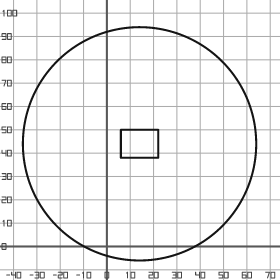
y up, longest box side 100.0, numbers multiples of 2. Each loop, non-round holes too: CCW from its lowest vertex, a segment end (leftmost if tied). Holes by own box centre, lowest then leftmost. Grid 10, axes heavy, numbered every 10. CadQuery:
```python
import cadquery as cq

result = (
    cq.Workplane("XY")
    .moveTo(14.0, 44.0)
    .circle(50.0)
    .moveTo(6.0, 38.0)
    .lineTo(22.0, 38.0)
    .lineTo(22.0, 50.0)
    .lineTo(6.0, 50.0)
    .close()
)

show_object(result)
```